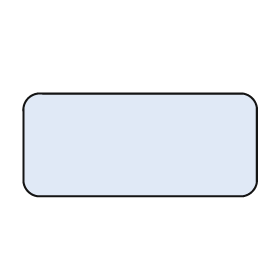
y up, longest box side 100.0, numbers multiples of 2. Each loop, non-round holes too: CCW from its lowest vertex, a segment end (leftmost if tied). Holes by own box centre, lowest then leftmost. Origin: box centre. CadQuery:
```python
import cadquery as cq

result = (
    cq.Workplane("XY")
    .moveTo(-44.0, -22.0)
    .lineTo(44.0, -22.0)
    .threePointArc((48.0, -20.0), (50.0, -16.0))
    .lineTo(50.0, 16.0)
    .threePointArc((48.0, 20.0), (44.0, 22.0))
    .lineTo(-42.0, 22.0)
    .threePointArc((-48.0, 20.0), (-50.0, 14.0))
    .lineTo(-50.0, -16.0)
    .threePointArc((-48.0, -20.0), (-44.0, -22.0))
    .close()
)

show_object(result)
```